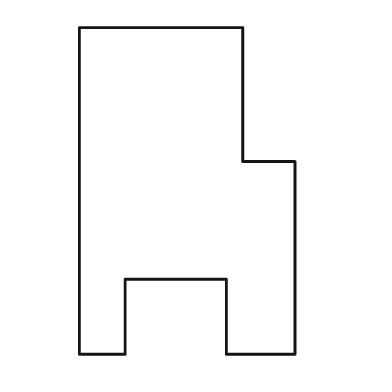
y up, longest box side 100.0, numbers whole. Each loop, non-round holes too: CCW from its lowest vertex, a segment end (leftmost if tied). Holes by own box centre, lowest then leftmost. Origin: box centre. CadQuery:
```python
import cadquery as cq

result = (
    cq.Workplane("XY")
    .moveTo(-33.0, -50.0)
    .lineTo(-19.0, -50.0)
    .lineTo(-19.0, -27.0)
    .lineTo(12.0, -27.0)
    .lineTo(12.0, -50.0)
    .lineTo(33.0, -50.0)
    .lineTo(33.0, 9.0)
    .lineTo(17.0, 9.0)
    .lineTo(17.0, 50.0)
    .lineTo(-33.0, 50.0)
    .close()
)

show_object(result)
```